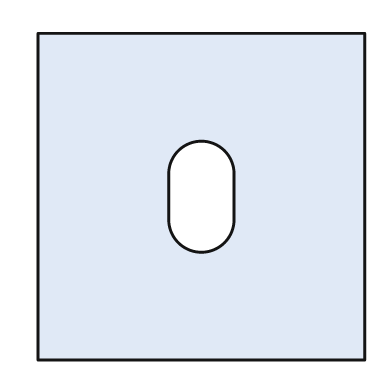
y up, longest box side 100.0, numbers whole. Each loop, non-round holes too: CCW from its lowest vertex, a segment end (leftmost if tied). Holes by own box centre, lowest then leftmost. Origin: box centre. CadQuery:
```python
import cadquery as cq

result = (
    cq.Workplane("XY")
    .moveTo(-50.0, -50.0)
    .lineTo(50.0, -50.0)
    .lineTo(50.0, 50.0)
    .lineTo(-50.0, 50.0)
    .close()
    .moveTo(-10.0, -7.0)
    .threePointArc((0.0, -17.0), (10.0, -7.0))
    .lineTo(10.0, 7.0)
    .threePointArc((0.0, 17.0), (-10.0, 7.0))
    .close()
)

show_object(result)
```